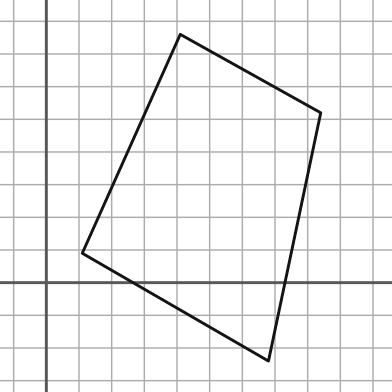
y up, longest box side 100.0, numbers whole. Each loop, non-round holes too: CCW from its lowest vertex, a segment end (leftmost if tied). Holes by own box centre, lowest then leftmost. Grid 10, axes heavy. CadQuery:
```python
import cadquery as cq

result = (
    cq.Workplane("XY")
    .moveTo(68.0, -24.0)
    .lineTo(84.0, 52.0)
    .lineTo(41.0, 76.0)
    .lineTo(11.0, 9.0)
    .close()
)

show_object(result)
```